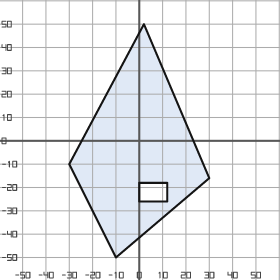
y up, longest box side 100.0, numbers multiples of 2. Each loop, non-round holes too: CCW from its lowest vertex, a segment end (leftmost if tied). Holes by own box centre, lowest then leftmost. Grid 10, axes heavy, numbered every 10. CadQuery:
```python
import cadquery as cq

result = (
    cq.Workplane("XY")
    .moveTo(-10.0, -50.0)
    .lineTo(30.0, -16.0)
    .lineTo(2.0, 50.0)
    .lineTo(-30.0, -10.0)
    .close()
    .moveTo(0.0, -26.0)
    .lineTo(12.0, -26.0)
    .lineTo(12.0, -18.0)
    .lineTo(0.0, -18.0)
    .close()
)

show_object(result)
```